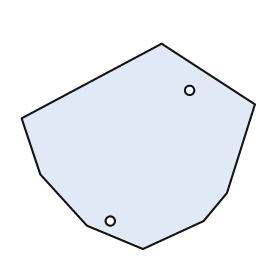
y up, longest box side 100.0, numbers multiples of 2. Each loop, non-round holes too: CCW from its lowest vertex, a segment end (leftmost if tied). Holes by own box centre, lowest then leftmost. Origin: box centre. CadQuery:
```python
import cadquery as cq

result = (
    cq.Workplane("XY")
    .moveTo(2.0, -44.0)
    .lineTo(28.0, -32.0)
    .lineTo(38.0, -20.0)
    .lineTo(50.0, 18.0)
    .lineTo(10.0, 44.0)
    .lineTo(-50.0, 12.0)
    .lineTo(-42.0, -12.0)
    .lineTo(-22.0, -34.0)
    .close()
    .moveTo(-12.0, -32.0)
    .circle(2.0)
    .moveTo(22.0, 24.0)
    .circle(2.0)
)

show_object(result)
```